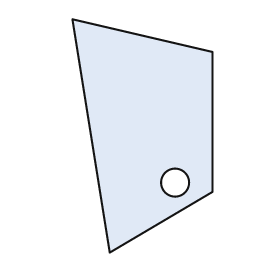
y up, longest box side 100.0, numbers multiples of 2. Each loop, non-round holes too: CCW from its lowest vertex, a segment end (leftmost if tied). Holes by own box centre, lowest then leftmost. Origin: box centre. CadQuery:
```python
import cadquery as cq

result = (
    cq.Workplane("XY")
    .moveTo(-14.0, -50.0)
    .lineTo(30.0, -24.0)
    .lineTo(30.0, 36.0)
    .lineTo(-30.0, 50.0)
    .close()
    .moveTo(14.0, -20.0)
    .circle(6.0)
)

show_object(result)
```